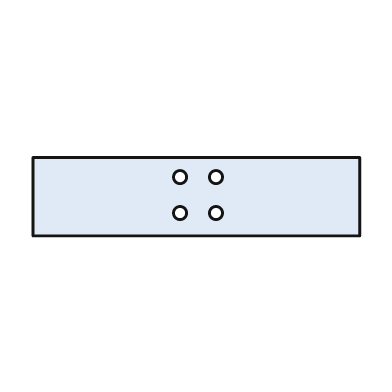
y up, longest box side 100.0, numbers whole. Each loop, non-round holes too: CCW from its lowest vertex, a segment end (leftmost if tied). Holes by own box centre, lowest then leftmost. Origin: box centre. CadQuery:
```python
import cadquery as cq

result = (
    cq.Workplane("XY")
    .moveTo(-50.0, -12.0)
    .lineTo(50.0, -12.0)
    .lineTo(50.0, 12.0)
    .lineTo(-50.0, 12.0)
    .close()
    .moveTo(-5.0, -5.0)
    .circle(2.0)
    .moveTo(6.0, -5.0)
    .circle(2.0)
    .moveTo(-5.0, 6.0)
    .circle(2.0)
    .moveTo(6.0, 6.0)
    .circle(2.0)
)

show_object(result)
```